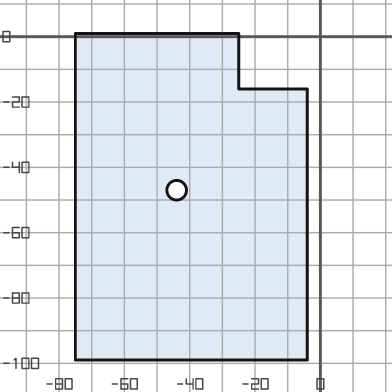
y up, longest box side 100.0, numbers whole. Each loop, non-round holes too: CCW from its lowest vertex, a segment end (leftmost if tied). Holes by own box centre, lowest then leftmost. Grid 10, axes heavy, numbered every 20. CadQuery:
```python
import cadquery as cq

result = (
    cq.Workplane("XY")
    .moveTo(-75.0, -99.0)
    .lineTo(-4.0, -99.0)
    .lineTo(-4.0, -16.0)
    .lineTo(-25.0, -16.0)
    .lineTo(-25.0, 1.0)
    .lineTo(-75.0, 1.0)
    .close()
    .moveTo(-44.0, -47.0)
    .circle(3.0)
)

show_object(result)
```